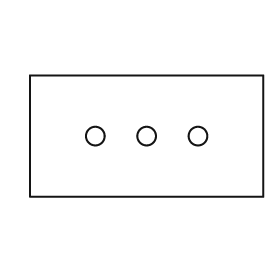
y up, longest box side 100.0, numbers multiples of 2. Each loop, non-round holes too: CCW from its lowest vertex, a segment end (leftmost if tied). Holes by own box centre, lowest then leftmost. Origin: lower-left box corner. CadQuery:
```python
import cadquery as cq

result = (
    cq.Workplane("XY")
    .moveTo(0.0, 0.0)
    .lineTo(100.0, 0.0)
    .lineTo(100.0, 52.0)
    .lineTo(0.0, 52.0)
    .close()
    .moveTo(28.0, 26.0)
    .circle(4.0)
    .moveTo(50.0, 26.0)
    .circle(4.0)
    .moveTo(72.0, 26.0)
    .circle(4.0)
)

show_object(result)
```